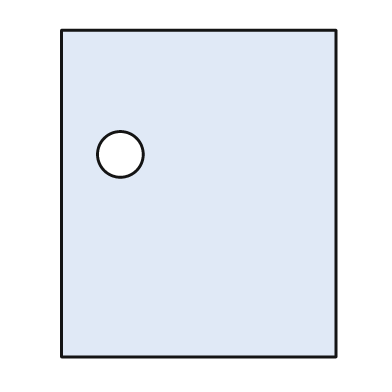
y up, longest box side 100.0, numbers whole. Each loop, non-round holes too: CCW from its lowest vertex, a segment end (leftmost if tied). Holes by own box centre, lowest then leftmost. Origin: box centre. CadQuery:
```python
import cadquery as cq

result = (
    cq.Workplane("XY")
    .moveTo(-42.0, -50.0)
    .lineTo(42.0, -50.0)
    .lineTo(42.0, 50.0)
    .lineTo(-42.0, 50.0)
    .close()
    .moveTo(-24.0, 12.0)
    .circle(7.0)
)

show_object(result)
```